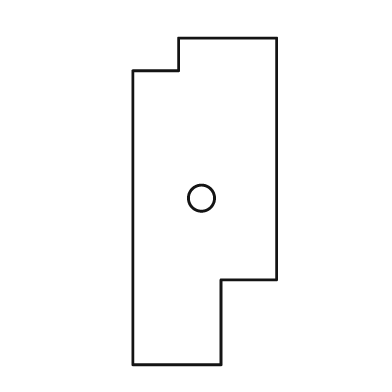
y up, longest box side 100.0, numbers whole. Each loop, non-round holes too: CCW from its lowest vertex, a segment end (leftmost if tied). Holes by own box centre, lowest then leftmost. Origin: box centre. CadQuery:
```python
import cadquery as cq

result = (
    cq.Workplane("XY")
    .moveTo(-22.0, -50.0)
    .lineTo(5.0, -50.0)
    .lineTo(5.0, -24.0)
    .lineTo(22.0, -24.0)
    .lineTo(22.0, 50.0)
    .lineTo(-8.0, 50.0)
    .lineTo(-8.0, 40.0)
    .lineTo(-22.0, 40.0)
    .close()
    .moveTo(-1.0, 1.0)
    .circle(4.0)
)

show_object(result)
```